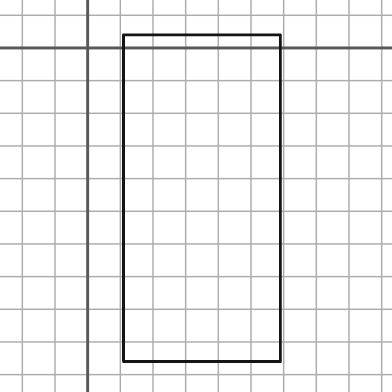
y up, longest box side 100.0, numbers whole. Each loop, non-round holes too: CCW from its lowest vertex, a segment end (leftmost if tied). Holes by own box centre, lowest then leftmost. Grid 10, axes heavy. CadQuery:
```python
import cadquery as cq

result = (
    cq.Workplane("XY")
    .moveTo(11.0, -96.0)
    .lineTo(59.0, -96.0)
    .lineTo(59.0, 4.0)
    .lineTo(11.0, 4.0)
    .close()
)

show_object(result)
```